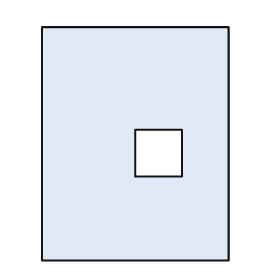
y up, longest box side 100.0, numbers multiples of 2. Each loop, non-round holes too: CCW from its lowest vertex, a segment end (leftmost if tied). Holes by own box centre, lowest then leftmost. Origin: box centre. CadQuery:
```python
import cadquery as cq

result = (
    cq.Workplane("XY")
    .moveTo(-40.0, -50.0)
    .lineTo(40.0, -50.0)
    .lineTo(40.0, 50.0)
    .lineTo(-40.0, 50.0)
    .close()
    .moveTo(0.0, -14.0)
    .lineTo(20.0, -14.0)
    .lineTo(20.0, 6.0)
    .lineTo(0.0, 6.0)
    .close()
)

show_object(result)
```